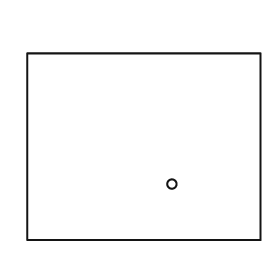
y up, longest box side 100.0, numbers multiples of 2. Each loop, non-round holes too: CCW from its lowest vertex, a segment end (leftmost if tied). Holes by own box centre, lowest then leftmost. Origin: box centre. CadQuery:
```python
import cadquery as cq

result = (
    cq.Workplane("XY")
    .moveTo(-50.0, -40.0)
    .lineTo(50.0, -40.0)
    .lineTo(50.0, 40.0)
    .lineTo(-50.0, 40.0)
    .close()
    .moveTo(12.0, -16.0)
    .circle(2.0)
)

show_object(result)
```